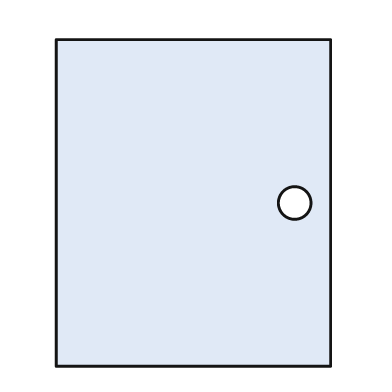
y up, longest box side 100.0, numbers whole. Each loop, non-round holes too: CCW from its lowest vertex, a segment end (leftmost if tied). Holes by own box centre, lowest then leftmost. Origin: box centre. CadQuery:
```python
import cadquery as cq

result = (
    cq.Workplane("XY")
    .moveTo(-42.0, -50.0)
    .lineTo(42.0, -50.0)
    .lineTo(42.0, 50.0)
    .lineTo(-42.0, 50.0)
    .close()
    .moveTo(31.0, 0.0)
    .circle(5.0)
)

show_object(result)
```